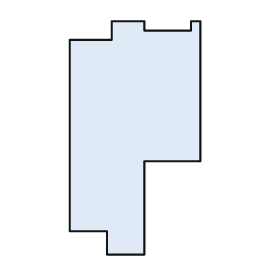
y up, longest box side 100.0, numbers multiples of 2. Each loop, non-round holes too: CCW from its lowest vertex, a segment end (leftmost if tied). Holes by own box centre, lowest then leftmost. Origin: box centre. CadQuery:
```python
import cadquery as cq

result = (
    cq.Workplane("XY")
    .moveTo(-12.0, -50.0)
    .lineTo(4.0, -50.0)
    .lineTo(4.0, -10.0)
    .lineTo(28.0, -10.0)
    .lineTo(28.0, 50.0)
    .lineTo(24.0, 50.0)
    .lineTo(24.0, 46.0)
    .lineTo(4.0, 46.0)
    .lineTo(4.0, 50.0)
    .lineTo(-10.0, 50.0)
    .lineTo(-10.0, 42.0)
    .lineTo(-28.0, 42.0)
    .lineTo(-28.0, -40.0)
    .lineTo(-12.0, -40.0)
    .close()
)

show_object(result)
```